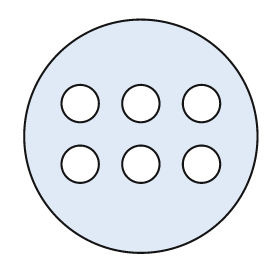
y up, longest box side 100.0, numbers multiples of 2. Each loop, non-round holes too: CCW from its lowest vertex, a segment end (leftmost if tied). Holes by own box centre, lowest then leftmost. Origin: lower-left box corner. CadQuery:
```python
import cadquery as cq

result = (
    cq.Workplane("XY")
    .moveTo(50.0, 50.0)
    .circle(50.0)
    .moveTo(24.0, 38.0)
    .circle(8.0)
    .moveTo(50.0, 38.0)
    .circle(8.0)
    .moveTo(76.0, 38.0)
    .circle(8.0)
    .moveTo(24.0, 64.0)
    .circle(8.0)
    .moveTo(50.0, 64.0)
    .circle(8.0)
    .moveTo(76.0, 64.0)
    .circle(8.0)
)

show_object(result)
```